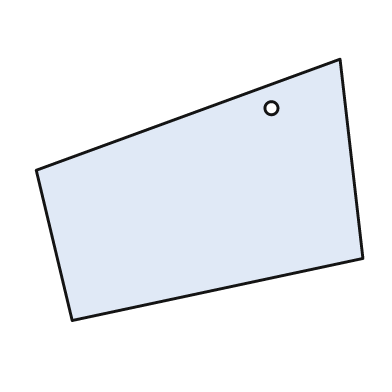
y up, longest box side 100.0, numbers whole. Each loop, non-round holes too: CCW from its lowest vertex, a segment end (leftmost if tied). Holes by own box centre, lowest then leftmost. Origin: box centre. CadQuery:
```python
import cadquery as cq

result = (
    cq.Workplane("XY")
    .moveTo(-39.0, -40.0)
    .lineTo(50.0, -21.0)
    .lineTo(43.0, 40.0)
    .lineTo(-50.0, 6.0)
    .close()
    .moveTo(22.0, 25.0)
    .circle(2.0)
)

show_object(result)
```